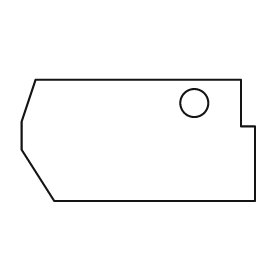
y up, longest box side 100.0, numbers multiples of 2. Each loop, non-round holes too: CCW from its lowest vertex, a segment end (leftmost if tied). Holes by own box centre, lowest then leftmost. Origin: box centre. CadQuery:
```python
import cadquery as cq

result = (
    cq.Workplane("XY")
    .moveTo(-36.0, -26.0)
    .lineTo(50.0, -26.0)
    .lineTo(50.0, 6.0)
    .lineTo(44.0, 6.0)
    .lineTo(44.0, 26.0)
    .lineTo(-44.0, 26.0)
    .lineTo(-50.0, 8.0)
    .lineTo(-50.0, -4.0)
    .close()
    .moveTo(24.0, 16.0)
    .circle(6.0)
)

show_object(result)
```